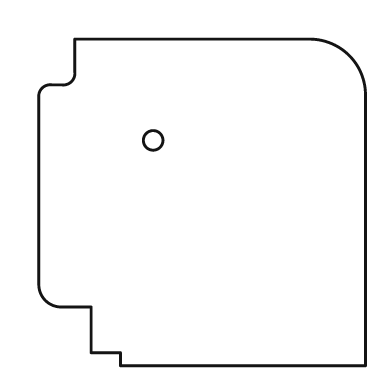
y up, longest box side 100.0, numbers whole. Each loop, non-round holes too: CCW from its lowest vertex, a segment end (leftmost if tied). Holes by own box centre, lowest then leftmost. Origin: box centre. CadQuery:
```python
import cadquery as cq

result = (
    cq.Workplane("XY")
    .moveTo(-25.0, -50.0)
    .lineTo(50.0, -50.0)
    .lineTo(50.0, 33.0)
    .threePointArc((45.0, 45.0), (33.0, 50.0))
    .lineTo(-39.0, 50.0)
    .lineTo(-39.0, 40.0)
    .threePointArc((-40.0, 37.0), (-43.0, 36.0))
    .lineTo(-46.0, 36.0)
    .threePointArc((-49.0, 35.0), (-50.0, 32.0))
    .lineTo(-50.0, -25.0)
    .threePointArc((-48.0, -30.0), (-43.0, -32.0))
    .lineTo(-34.0, -32.0)
    .lineTo(-34.0, -46.0)
    .lineTo(-25.0, -46.0)
    .close()
    .moveTo(-15.0, 19.0)
    .circle(3.0)
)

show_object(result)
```